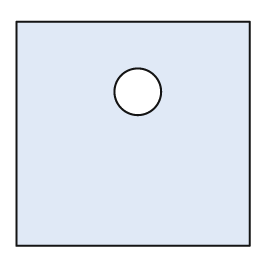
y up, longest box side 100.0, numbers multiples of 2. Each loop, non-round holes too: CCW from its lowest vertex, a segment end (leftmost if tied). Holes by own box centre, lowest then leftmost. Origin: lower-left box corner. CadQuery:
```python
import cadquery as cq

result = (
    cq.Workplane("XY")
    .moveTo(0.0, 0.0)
    .lineTo(100.0, 0.0)
    .lineTo(100.0, 96.0)
    .lineTo(0.0, 96.0)
    .close()
    .moveTo(52.0, 66.0)
    .circle(10.0)
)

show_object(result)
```